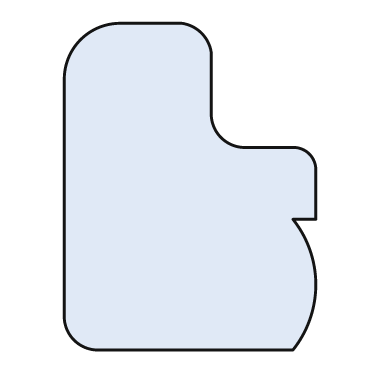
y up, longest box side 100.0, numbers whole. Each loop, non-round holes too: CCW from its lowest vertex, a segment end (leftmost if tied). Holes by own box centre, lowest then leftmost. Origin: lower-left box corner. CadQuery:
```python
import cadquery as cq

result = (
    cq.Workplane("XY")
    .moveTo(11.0, 0.0)
    .lineTo(70.0, 0.0)
    .threePointArc((77.0, 20.0), (70.0, 40.0))
    .lineTo(77.0, 40.0)
    .lineTo(77.0, 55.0)
    .threePointArc((75.0, 60.0), (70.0, 62.0))
    .lineTo(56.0, 62.0)
    .threePointArc((48.0, 65.0), (45.0, 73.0))
    .lineTo(45.0, 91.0)
    .threePointArc((42.0, 97.0), (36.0, 100.0))
    .lineTo(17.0, 100.0)
    .threePointArc((5.0, 95.0), (0.0, 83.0))
    .lineTo(0.0, 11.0)
    .threePointArc((3.0, 3.0), (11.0, 0.0))
    .close()
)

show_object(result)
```